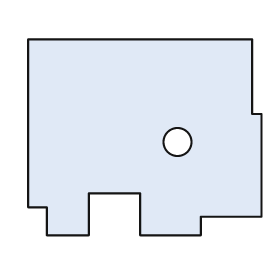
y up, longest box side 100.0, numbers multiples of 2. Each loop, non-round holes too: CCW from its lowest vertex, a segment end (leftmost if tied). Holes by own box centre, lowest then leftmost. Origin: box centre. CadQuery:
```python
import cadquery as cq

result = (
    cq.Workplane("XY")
    .moveTo(-42.0, -42.0)
    .lineTo(-24.0, -42.0)
    .lineTo(-24.0, -24.0)
    .lineTo(-2.0, -24.0)
    .lineTo(-2.0, -42.0)
    .lineTo(24.0, -42.0)
    .lineTo(24.0, -34.0)
    .lineTo(50.0, -34.0)
    .lineTo(50.0, 10.0)
    .lineTo(46.0, 10.0)
    .lineTo(46.0, 42.0)
    .lineTo(-50.0, 42.0)
    .lineTo(-50.0, -30.0)
    .lineTo(-42.0, -30.0)
    .close()
    .moveTo(14.0, -2.0)
    .circle(6.0)
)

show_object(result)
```